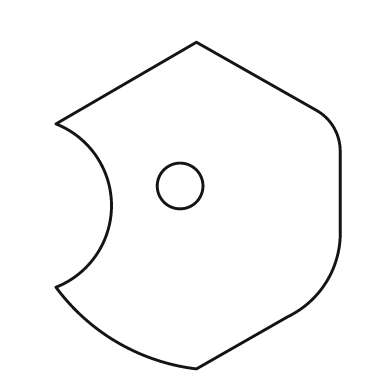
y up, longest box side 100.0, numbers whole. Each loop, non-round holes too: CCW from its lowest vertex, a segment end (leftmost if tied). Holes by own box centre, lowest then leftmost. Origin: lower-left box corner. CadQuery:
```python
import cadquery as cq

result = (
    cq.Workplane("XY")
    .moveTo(43.0, 0.0)
    .lineTo(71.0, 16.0)
    .threePointArc((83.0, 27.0), (87.0, 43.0))
    .lineTo(87.0, 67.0)
    .threePointArc((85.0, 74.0), (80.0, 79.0))
    .lineTo(43.0, 100.0)
    .lineTo(0.0, 75.0)
    .threePointArc((17.0, 50.0), (0.0, 25.0))
    .threePointArc((19.0, 8.0), (43.0, 0.0))
    .close()
    .moveTo(38.0, 56.0)
    .circle(7.0)
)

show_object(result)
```